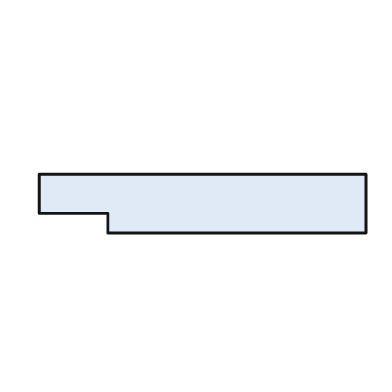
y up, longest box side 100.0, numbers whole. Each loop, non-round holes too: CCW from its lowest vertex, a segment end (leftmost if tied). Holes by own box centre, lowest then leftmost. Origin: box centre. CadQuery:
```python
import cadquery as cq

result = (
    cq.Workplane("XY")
    .moveTo(-29.0, -9.0)
    .lineTo(50.0, -9.0)
    .lineTo(50.0, 9.0)
    .lineTo(-50.0, 9.0)
    .lineTo(-50.0, -3.0)
    .lineTo(-29.0, -3.0)
    .close()
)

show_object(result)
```